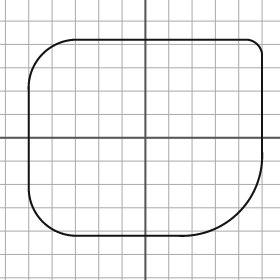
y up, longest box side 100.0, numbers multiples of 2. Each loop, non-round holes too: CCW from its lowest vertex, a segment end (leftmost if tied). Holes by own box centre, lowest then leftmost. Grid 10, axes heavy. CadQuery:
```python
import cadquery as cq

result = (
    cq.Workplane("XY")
    .moveTo(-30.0, -42.0)
    .lineTo(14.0, -42.0)
    .threePointArc((40.0, -32.0), (50.0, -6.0))
    .lineTo(50.0, 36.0)
    .threePointArc((48.0, 40.0), (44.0, 42.0))
    .lineTo(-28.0, 42.0)
    .threePointArc((-44.0, 36.0), (-50.0, 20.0))
    .lineTo(-50.0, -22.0)
    .threePointArc((-44.0, -36.0), (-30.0, -42.0))
    .close()
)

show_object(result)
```